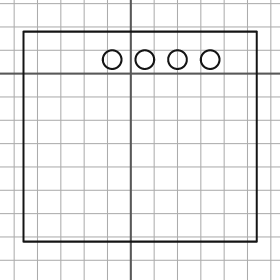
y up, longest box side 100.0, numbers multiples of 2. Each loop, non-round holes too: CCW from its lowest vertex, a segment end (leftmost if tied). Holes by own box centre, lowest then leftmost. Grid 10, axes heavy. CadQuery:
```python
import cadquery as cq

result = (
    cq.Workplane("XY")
    .moveTo(-46.0, -72.0)
    .lineTo(54.0, -72.0)
    .lineTo(54.0, 18.0)
    .lineTo(-46.0, 18.0)
    .close()
    .moveTo(-8.0, 6.0)
    .circle(4.0)
    .moveTo(6.0, 6.0)
    .circle(4.0)
    .moveTo(20.0, 6.0)
    .circle(4.0)
    .moveTo(34.0, 6.0)
    .circle(4.0)
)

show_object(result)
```